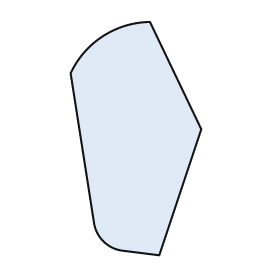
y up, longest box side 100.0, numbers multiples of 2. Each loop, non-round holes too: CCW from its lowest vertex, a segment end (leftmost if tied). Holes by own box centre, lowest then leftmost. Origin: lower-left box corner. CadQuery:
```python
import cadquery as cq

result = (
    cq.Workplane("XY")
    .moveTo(38.0, 0.0)
    .lineTo(56.0, 54.0)
    .lineTo(34.0, 100.0)
    .threePointArc((14.0, 94.0), (0.0, 78.0))
    .lineTo(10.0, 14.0)
    .threePointArc((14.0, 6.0), (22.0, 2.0))
    .close()
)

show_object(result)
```